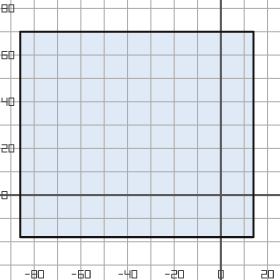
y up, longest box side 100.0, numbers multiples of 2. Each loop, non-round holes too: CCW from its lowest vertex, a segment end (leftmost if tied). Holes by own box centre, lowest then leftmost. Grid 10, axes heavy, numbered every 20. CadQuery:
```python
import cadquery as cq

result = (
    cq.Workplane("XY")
    .moveTo(-86.0, -18.0)
    .lineTo(14.0, -18.0)
    .lineTo(14.0, 70.0)
    .lineTo(-86.0, 70.0)
    .close()
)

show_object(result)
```